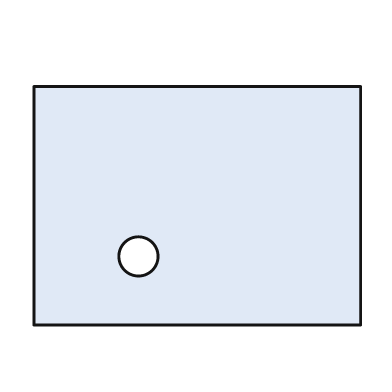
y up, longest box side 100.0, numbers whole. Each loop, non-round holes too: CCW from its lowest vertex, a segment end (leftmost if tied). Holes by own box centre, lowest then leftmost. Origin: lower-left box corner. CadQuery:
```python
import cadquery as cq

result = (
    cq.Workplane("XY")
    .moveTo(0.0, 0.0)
    .lineTo(100.0, 0.0)
    .lineTo(100.0, 73.0)
    .lineTo(0.0, 73.0)
    .close()
    .moveTo(32.0, 21.0)
    .circle(6.0)
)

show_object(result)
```